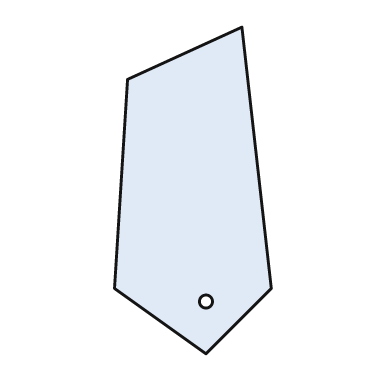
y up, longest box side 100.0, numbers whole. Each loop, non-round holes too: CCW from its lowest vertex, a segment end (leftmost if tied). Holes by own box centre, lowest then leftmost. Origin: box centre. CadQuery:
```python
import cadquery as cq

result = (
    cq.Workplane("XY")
    .moveTo(4.0, -50.0)
    .lineTo(24.0, -30.0)
    .lineTo(15.0, 50.0)
    .lineTo(-20.0, 34.0)
    .lineTo(-24.0, -30.0)
    .close()
    .moveTo(4.0, -34.0)
    .circle(2.0)
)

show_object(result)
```